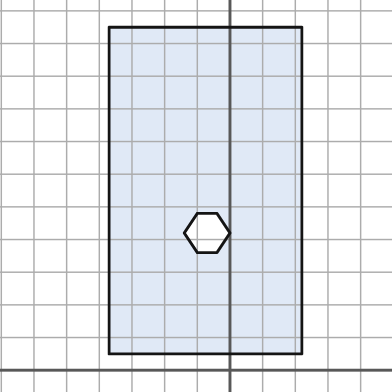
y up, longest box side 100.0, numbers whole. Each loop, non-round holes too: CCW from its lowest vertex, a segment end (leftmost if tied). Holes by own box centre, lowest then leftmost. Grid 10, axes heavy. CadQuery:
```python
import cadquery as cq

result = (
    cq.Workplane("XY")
    .moveTo(-37.0, 5.0)
    .lineTo(22.0, 5.0)
    .lineTo(22.0, 105.0)
    .lineTo(-37.0, 105.0)
    .close()
    .moveTo(-10.0, 36.0)
    .lineTo(-4.0, 36.0)
    .lineTo(0.0, 42.0)
    .lineTo(-4.0, 48.0)
    .lineTo(-10.0, 48.0)
    .lineTo(-14.0, 42.0)
    .close()
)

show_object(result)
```